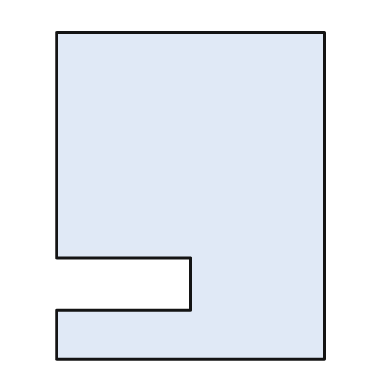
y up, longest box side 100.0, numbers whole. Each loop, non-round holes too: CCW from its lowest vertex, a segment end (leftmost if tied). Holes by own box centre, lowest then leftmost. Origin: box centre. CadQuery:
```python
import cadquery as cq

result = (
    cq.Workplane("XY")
    .moveTo(-41.0, -50.0)
    .lineTo(41.0, -50.0)
    .lineTo(41.0, 50.0)
    .lineTo(-41.0, 50.0)
    .lineTo(-41.0, -19.0)
    .lineTo(0.0, -19.0)
    .lineTo(0.0, -35.0)
    .lineTo(-41.0, -35.0)
    .close()
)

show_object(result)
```